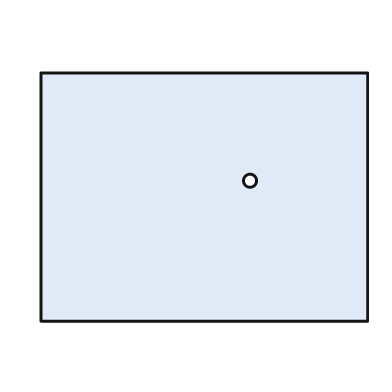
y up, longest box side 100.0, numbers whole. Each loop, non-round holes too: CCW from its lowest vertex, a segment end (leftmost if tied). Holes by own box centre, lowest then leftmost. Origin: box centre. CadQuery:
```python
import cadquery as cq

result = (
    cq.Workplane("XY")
    .moveTo(-50.0, -38.0)
    .lineTo(50.0, -38.0)
    .lineTo(50.0, 38.0)
    .lineTo(-50.0, 38.0)
    .close()
    .moveTo(14.0, 5.0)
    .circle(2.0)
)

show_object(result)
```